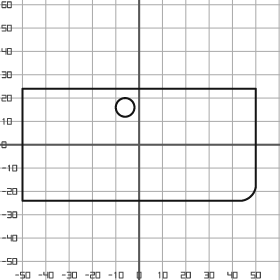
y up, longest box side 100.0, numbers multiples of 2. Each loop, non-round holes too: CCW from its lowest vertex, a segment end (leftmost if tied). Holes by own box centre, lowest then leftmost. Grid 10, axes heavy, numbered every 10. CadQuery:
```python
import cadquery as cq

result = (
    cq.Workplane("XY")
    .moveTo(-50.0, -24.0)
    .lineTo(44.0, -24.0)
    .threePointArc((48.0, -22.0), (50.0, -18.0))
    .lineTo(50.0, 24.0)
    .lineTo(-50.0, 24.0)
    .close()
    .moveTo(-6.0, 16.0)
    .circle(4.0)
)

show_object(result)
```